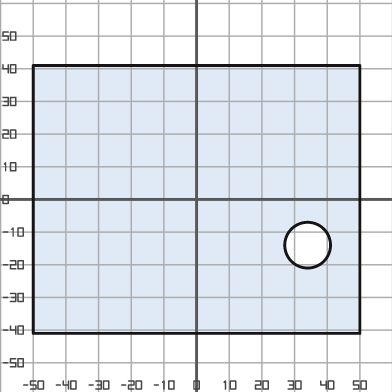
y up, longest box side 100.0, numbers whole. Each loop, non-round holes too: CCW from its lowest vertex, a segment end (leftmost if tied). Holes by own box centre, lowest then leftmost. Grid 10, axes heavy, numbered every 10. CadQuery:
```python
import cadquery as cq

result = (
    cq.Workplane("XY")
    .moveTo(-50.0, -41.0)
    .lineTo(50.0, -41.0)
    .lineTo(50.0, 41.0)
    .lineTo(-50.0, 41.0)
    .close()
    .moveTo(34.0, -14.0)
    .circle(7.0)
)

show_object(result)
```